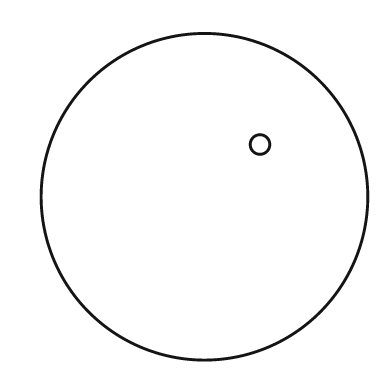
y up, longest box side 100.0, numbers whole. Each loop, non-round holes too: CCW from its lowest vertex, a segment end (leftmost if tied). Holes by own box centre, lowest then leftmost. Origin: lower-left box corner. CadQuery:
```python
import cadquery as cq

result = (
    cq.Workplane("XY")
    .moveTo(50.0, 50.0)
    .circle(50.0)
    .moveTo(67.0, 66.0)
    .circle(3.0)
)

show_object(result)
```